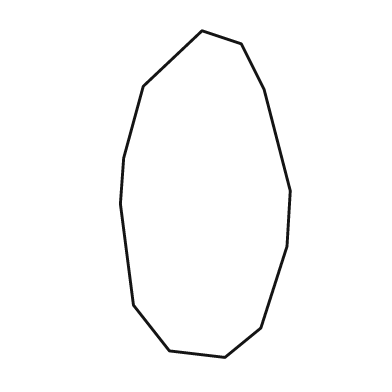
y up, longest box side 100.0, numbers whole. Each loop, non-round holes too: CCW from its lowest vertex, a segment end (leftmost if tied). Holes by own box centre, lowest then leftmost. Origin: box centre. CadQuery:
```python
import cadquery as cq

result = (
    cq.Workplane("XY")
    .moveTo(6.0, -50.0)
    .lineTo(17.0, -41.0)
    .lineTo(25.0, -16.0)
    .lineTo(26.0, 1.0)
    .lineTo(18.0, 32.0)
    .lineTo(11.0, 46.0)
    .lineTo(-1.0, 50.0)
    .lineTo(-19.0, 33.0)
    .lineTo(-25.0, 11.0)
    .lineTo(-26.0, -3.0)
    .lineTo(-22.0, -34.0)
    .lineTo(-11.0, -48.0)
    .close()
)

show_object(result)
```